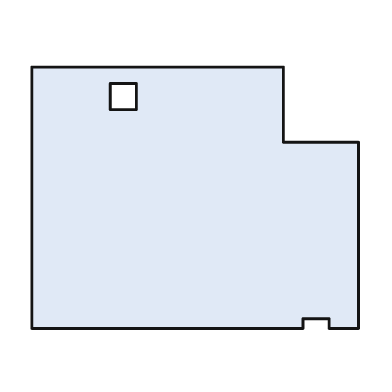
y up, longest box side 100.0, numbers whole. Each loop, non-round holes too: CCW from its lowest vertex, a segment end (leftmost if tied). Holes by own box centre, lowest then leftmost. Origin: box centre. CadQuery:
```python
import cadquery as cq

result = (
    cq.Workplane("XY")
    .moveTo(-50.0, -40.0)
    .lineTo(33.0, -40.0)
    .lineTo(33.0, -37.0)
    .lineTo(41.0, -37.0)
    .lineTo(41.0, -40.0)
    .lineTo(50.0, -40.0)
    .lineTo(50.0, 17.0)
    .lineTo(27.0, 17.0)
    .lineTo(27.0, 40.0)
    .lineTo(-50.0, 40.0)
    .close()
    .moveTo(-26.0, 27.0)
    .lineTo(-18.0, 27.0)
    .lineTo(-18.0, 35.0)
    .lineTo(-26.0, 35.0)
    .close()
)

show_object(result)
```